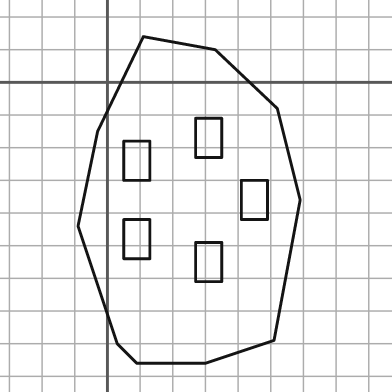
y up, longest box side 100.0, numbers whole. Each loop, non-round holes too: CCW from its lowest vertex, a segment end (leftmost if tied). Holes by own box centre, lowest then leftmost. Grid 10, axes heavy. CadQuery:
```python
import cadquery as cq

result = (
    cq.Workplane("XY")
    .moveTo(9.0, -86.0)
    .lineTo(30.0, -86.0)
    .lineTo(51.0, -79.0)
    .lineTo(59.0, -36.0)
    .lineTo(52.0, -8.0)
    .lineTo(33.0, 10.0)
    .lineTo(11.0, 14.0)
    .lineTo(-3.0, -15.0)
    .lineTo(-9.0, -44.0)
    .lineTo(3.0, -80.0)
    .close()
    .moveTo(27.0, -61.0)
    .lineTo(35.0, -61.0)
    .lineTo(35.0, -49.0)
    .lineTo(27.0, -49.0)
    .close()
    .moveTo(5.0, -54.0)
    .lineTo(13.0, -54.0)
    .lineTo(13.0, -42.0)
    .lineTo(5.0, -42.0)
    .close()
    .moveTo(41.0, -42.0)
    .lineTo(49.0, -42.0)
    .lineTo(49.0, -30.0)
    .lineTo(41.0, -30.0)
    .close()
    .moveTo(5.0, -30.0)
    .lineTo(13.0, -30.0)
    .lineTo(13.0, -18.0)
    .lineTo(5.0, -18.0)
    .close()
    .moveTo(27.0, -23.0)
    .lineTo(35.0, -23.0)
    .lineTo(35.0, -11.0)
    .lineTo(27.0, -11.0)
    .close()
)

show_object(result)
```